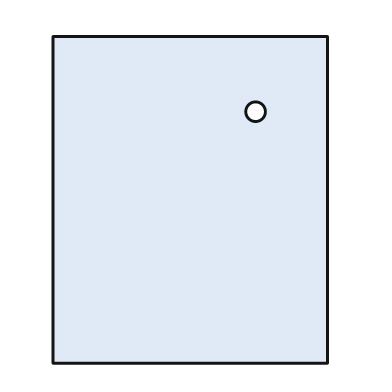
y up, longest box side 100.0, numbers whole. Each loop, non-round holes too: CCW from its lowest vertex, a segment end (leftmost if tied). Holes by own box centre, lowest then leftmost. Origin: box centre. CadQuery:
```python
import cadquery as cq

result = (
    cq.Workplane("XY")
    .moveTo(-42.0, -50.0)
    .lineTo(42.0, -50.0)
    .lineTo(42.0, 50.0)
    .lineTo(-42.0, 50.0)
    .close()
    .moveTo(20.0, 27.0)
    .circle(3.0)
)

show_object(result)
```